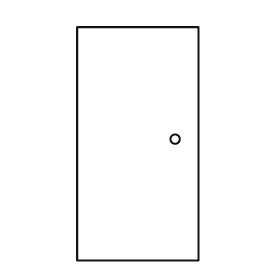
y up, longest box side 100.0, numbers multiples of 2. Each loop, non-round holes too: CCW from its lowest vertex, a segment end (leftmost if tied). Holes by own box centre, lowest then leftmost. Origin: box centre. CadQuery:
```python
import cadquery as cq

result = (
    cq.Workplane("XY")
    .moveTo(-26.0, -50.0)
    .lineTo(26.0, -50.0)
    .lineTo(26.0, 50.0)
    .lineTo(-26.0, 50.0)
    .close()
    .moveTo(16.0, 2.0)
    .circle(2.0)
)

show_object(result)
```